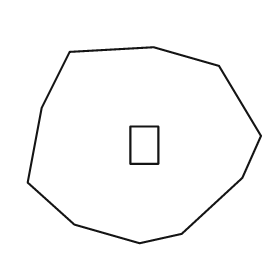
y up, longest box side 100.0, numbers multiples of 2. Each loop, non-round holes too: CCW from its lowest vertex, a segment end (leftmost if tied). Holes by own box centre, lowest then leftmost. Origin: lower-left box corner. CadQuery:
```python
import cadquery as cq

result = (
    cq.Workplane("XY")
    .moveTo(48.0, 0.0)
    .lineTo(66.0, 4.0)
    .lineTo(92.0, 28.0)
    .lineTo(100.0, 46.0)
    .lineTo(82.0, 76.0)
    .lineTo(54.0, 84.0)
    .lineTo(18.0, 82.0)
    .lineTo(6.0, 58.0)
    .lineTo(0.0, 26.0)
    .lineTo(20.0, 8.0)
    .close()
    .moveTo(44.0, 34.0)
    .lineTo(56.0, 34.0)
    .lineTo(56.0, 50.0)
    .lineTo(44.0, 50.0)
    .close()
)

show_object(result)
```